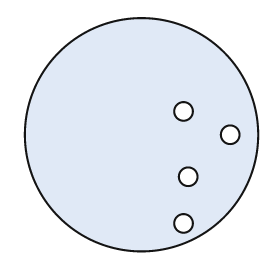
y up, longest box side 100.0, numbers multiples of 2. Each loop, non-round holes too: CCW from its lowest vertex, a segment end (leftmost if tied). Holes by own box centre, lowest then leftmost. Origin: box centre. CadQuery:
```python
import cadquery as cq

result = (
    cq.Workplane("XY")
    .moveTo(0.0, 0.0)
    .circle(50.0)
    .moveTo(18.0, -38.0)
    .circle(4.0)
    .moveTo(20.0, -18.0)
    .circle(4.0)
    .moveTo(38.0, 0.0)
    .circle(4.0)
    .moveTo(18.0, 10.0)
    .circle(4.0)
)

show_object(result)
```